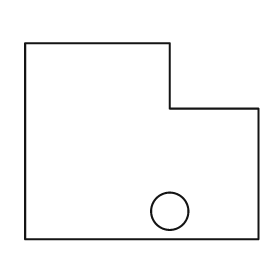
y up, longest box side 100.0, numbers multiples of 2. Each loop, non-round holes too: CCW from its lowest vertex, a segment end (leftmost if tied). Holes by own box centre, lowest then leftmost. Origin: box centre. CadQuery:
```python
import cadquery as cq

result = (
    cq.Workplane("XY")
    .moveTo(-50.0, -42.0)
    .lineTo(50.0, -42.0)
    .lineTo(50.0, 14.0)
    .lineTo(12.0, 14.0)
    .lineTo(12.0, 42.0)
    .lineTo(-50.0, 42.0)
    .close()
    .moveTo(12.0, -30.0)
    .circle(8.0)
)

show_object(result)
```